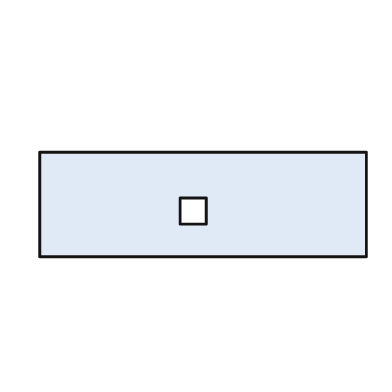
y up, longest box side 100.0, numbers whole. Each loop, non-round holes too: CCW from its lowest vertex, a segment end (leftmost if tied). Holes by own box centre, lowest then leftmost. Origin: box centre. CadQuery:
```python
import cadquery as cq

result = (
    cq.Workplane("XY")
    .moveTo(-50.0, -16.0)
    .lineTo(50.0, -16.0)
    .lineTo(50.0, 16.0)
    .lineTo(-50.0, 16.0)
    .close()
    .moveTo(-7.0, -6.0)
    .lineTo(1.0, -6.0)
    .lineTo(1.0, 2.0)
    .lineTo(-7.0, 2.0)
    .close()
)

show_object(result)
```